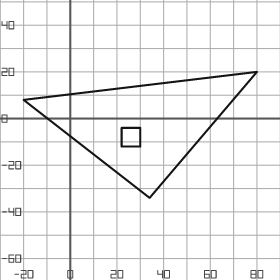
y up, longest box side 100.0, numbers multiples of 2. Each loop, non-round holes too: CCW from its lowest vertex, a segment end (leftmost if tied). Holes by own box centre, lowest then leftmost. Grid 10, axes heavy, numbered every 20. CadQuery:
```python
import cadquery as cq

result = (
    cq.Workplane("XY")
    .moveTo(34.0, -34.0)
    .lineTo(80.0, 20.0)
    .lineTo(-20.0, 8.0)
    .close()
    .moveTo(22.0, -12.0)
    .lineTo(30.0, -12.0)
    .lineTo(30.0, -4.0)
    .lineTo(22.0, -4.0)
    .close()
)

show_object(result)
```